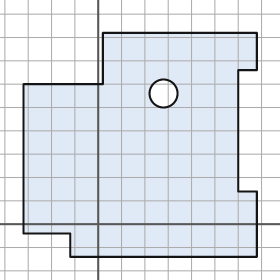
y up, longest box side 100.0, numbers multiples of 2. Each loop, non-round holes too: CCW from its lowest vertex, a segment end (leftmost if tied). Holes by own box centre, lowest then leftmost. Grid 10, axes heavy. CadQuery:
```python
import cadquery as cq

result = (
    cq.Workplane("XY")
    .moveTo(-12.0, -14.0)
    .lineTo(68.0, -14.0)
    .lineTo(68.0, 14.0)
    .lineTo(60.0, 14.0)
    .lineTo(60.0, 66.0)
    .lineTo(68.0, 66.0)
    .lineTo(68.0, 82.0)
    .lineTo(2.0, 82.0)
    .lineTo(2.0, 60.0)
    .lineTo(-32.0, 60.0)
    .lineTo(-32.0, -4.0)
    .lineTo(-12.0, -4.0)
    .close()
    .moveTo(28.0, 56.0)
    .circle(6.0)
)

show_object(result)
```